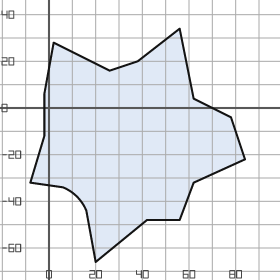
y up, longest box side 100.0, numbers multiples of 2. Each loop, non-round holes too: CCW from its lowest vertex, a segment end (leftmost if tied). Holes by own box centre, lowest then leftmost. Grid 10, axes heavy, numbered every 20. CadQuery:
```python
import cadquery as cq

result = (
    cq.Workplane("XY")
    .moveTo(20.0, -66.0)
    .lineTo(42.0, -48.0)
    .lineTo(56.0, -48.0)
    .lineTo(62.0, -32.0)
    .lineTo(84.0, -22.0)
    .lineTo(78.0, -4.0)
    .lineTo(62.0, 4.0)
    .lineTo(56.0, 34.0)
    .lineTo(38.0, 20.0)
    .lineTo(26.0, 16.0)
    .lineTo(2.0, 28.0)
    .lineTo(-2.0, 6.0)
    .lineTo(-2.0, -12.0)
    .lineTo(-8.0, -32.0)
    .lineTo(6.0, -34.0)
    .threePointArc((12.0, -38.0), (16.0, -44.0))
    .close()
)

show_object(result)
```